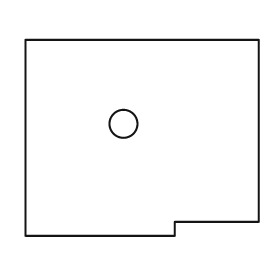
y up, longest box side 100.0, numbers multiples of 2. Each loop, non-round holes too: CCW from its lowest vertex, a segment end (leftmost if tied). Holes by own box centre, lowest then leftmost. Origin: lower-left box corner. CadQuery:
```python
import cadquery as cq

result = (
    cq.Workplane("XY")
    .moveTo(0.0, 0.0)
    .lineTo(64.0, 0.0)
    .lineTo(64.0, 6.0)
    .lineTo(100.0, 6.0)
    .lineTo(100.0, 84.0)
    .lineTo(0.0, 84.0)
    .close()
    .moveTo(42.0, 48.0)
    .circle(6.0)
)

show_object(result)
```